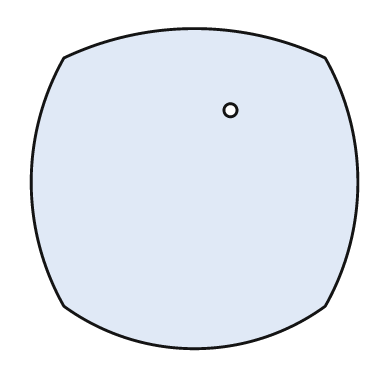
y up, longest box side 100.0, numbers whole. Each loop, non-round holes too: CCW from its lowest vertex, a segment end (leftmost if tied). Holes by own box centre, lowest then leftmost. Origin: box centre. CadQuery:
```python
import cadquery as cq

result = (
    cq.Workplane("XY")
    .moveTo(-40.0, -36.0)
    .threePointArc((0.0, -49.0), (40.0, -36.0))
    .threePointArc((50.0, 2.0), (40.0, 40.0))
    .threePointArc((0.0, 49.0), (-40.0, 40.0))
    .threePointArc((-50.0, 2.0), (-40.0, -36.0))
    .close()
    .moveTo(11.0, 24.0)
    .circle(2.0)
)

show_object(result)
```